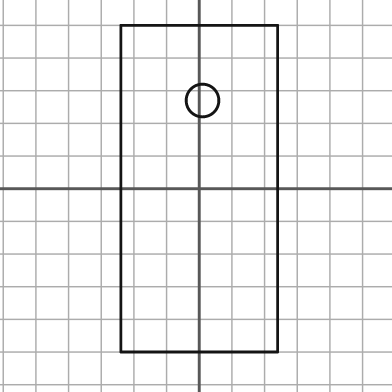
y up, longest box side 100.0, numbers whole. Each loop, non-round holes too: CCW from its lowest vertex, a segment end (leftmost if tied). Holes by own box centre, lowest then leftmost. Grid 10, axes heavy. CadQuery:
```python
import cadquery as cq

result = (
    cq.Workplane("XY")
    .moveTo(-24.0, -50.0)
    .lineTo(24.0, -50.0)
    .lineTo(24.0, 50.0)
    .lineTo(-24.0, 50.0)
    .close()
    .moveTo(1.0, 27.0)
    .circle(5.0)
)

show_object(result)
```